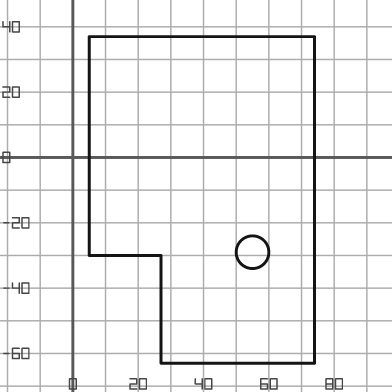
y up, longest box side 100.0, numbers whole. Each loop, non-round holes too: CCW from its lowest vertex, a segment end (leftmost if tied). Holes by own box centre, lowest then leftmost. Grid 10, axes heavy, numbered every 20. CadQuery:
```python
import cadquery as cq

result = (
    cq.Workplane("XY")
    .moveTo(27.0, -63.0)
    .lineTo(74.0, -63.0)
    .lineTo(74.0, 37.0)
    .lineTo(5.0, 37.0)
    .lineTo(5.0, -30.0)
    .lineTo(27.0, -30.0)
    .close()
    .moveTo(55.0, -29.0)
    .circle(5.0)
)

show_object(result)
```